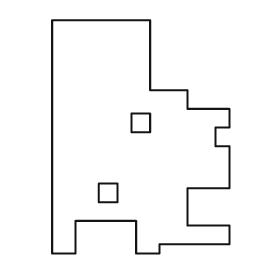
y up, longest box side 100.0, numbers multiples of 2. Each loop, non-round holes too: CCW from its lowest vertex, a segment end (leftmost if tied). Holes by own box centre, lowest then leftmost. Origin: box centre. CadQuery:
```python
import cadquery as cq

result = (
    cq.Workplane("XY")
    .moveTo(-38.0, -50.0)
    .lineTo(-28.0, -50.0)
    .lineTo(-28.0, -36.0)
    .lineTo(-2.0, -36.0)
    .lineTo(-2.0, -50.0)
    .lineTo(8.0, -50.0)
    .lineTo(8.0, -46.0)
    .lineTo(38.0, -46.0)
    .lineTo(38.0, -38.0)
    .lineTo(20.0, -38.0)
    .lineTo(20.0, -22.0)
    .lineTo(38.0, -22.0)
    .lineTo(38.0, -4.0)
    .lineTo(32.0, -4.0)
    .lineTo(32.0, 4.0)
    .lineTo(38.0, 4.0)
    .lineTo(38.0, 12.0)
    .lineTo(20.0, 12.0)
    .lineTo(20.0, 20.0)
    .lineTo(4.0, 20.0)
    .lineTo(4.0, 50.0)
    .lineTo(-38.0, 50.0)
    .close()
    .moveTo(-18.0, -28.0)
    .lineTo(-10.0, -28.0)
    .lineTo(-10.0, -20.0)
    .lineTo(-18.0, -20.0)
    .close()
    .moveTo(-4.0, 2.0)
    .lineTo(4.0, 2.0)
    .lineTo(4.0, 10.0)
    .lineTo(-4.0, 10.0)
    .close()
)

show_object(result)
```